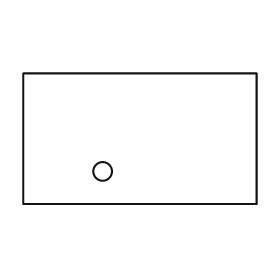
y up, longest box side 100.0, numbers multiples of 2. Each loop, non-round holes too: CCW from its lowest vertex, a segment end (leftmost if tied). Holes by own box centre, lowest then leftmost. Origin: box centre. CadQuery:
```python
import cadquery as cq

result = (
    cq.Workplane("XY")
    .moveTo(-50.0, -28.0)
    .lineTo(50.0, -28.0)
    .lineTo(50.0, 28.0)
    .lineTo(-50.0, 28.0)
    .close()
    .moveTo(-16.0, -14.0)
    .circle(4.0)
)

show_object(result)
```